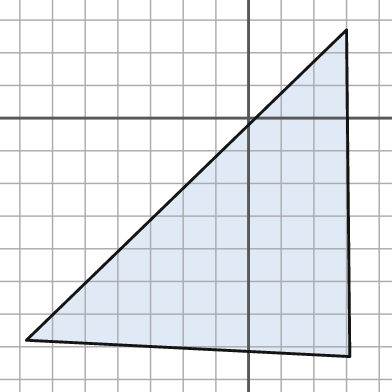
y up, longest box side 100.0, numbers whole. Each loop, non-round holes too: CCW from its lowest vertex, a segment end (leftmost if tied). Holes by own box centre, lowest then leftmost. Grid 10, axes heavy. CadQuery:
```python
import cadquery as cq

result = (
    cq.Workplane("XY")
    .moveTo(31.0, -73.0)
    .lineTo(30.0, 27.0)
    .lineTo(-68.0, -68.0)
    .close()
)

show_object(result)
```